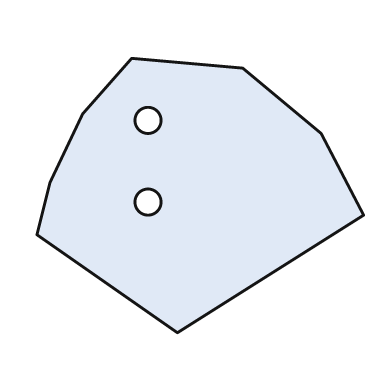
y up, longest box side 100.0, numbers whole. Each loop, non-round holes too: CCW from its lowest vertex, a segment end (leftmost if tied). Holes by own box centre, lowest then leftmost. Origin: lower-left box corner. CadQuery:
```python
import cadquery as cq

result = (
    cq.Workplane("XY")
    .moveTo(43.0, 0.0)
    .lineTo(100.0, 36.0)
    .lineTo(87.0, 61.0)
    .lineTo(63.0, 81.0)
    .lineTo(29.0, 84.0)
    .lineTo(14.0, 67.0)
    .lineTo(4.0, 46.0)
    .lineTo(0.0, 30.0)
    .close()
    .moveTo(34.0, 40.0)
    .circle(4.0)
    .moveTo(34.0, 65.0)
    .circle(4.0)
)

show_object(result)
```